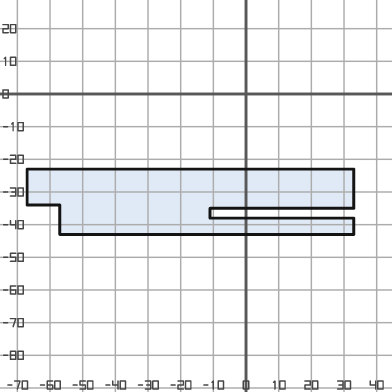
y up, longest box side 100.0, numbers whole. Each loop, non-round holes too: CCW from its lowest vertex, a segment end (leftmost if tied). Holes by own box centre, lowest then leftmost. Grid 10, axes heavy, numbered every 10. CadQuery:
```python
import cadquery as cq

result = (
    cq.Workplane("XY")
    .moveTo(-57.0, -43.0)
    .lineTo(33.0, -43.0)
    .lineTo(33.0, -38.0)
    .lineTo(-11.0, -38.0)
    .lineTo(-11.0, -35.0)
    .lineTo(33.0, -35.0)
    .lineTo(33.0, -23.0)
    .lineTo(-67.0, -23.0)
    .lineTo(-67.0, -34.0)
    .lineTo(-57.0, -34.0)
    .close()
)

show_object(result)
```